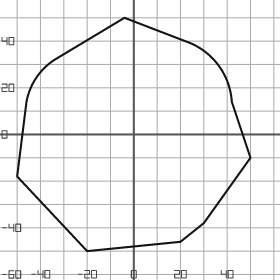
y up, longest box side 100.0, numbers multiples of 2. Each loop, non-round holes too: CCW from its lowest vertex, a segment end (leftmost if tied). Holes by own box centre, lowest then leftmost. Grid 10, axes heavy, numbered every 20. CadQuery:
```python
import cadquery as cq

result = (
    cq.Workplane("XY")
    .moveTo(-20.0, -50.0)
    .lineTo(20.0, -46.0)
    .lineTo(30.0, -38.0)
    .lineTo(50.0, -10.0)
    .lineTo(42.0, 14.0)
    .threePointArc((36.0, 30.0), (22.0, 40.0))
    .lineTo(-4.0, 50.0)
    .lineTo(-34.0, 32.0)
    .threePointArc((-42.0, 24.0), (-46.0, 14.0))
    .lineTo(-50.0, -18.0)
    .close()
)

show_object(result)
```